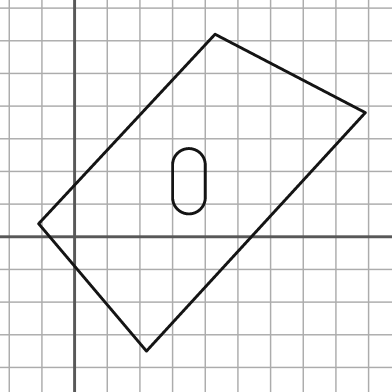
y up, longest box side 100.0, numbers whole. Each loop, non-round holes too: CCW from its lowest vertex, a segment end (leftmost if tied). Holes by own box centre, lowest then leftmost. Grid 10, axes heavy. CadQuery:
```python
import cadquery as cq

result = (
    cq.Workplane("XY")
    .moveTo(22.0, -35.0)
    .lineTo(89.0, 38.0)
    .lineTo(43.0, 62.0)
    .lineTo(-11.0, 4.0)
    .close()
    .moveTo(30.0, 12.0)
    .threePointArc((35.0, 7.0), (40.0, 12.0))
    .lineTo(40.0, 22.0)
    .threePointArc((35.0, 27.0), (30.0, 22.0))
    .close()
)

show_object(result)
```